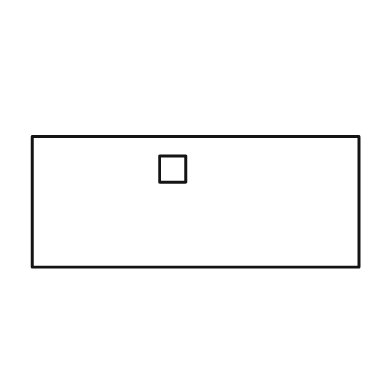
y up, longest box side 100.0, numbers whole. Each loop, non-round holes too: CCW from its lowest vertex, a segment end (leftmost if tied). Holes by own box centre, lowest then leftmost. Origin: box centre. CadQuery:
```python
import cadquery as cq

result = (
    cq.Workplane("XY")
    .moveTo(-50.0, -20.0)
    .lineTo(50.0, -20.0)
    .lineTo(50.0, 20.0)
    .lineTo(-50.0, 20.0)
    .close()
    .moveTo(-11.0, 6.0)
    .lineTo(-3.0, 6.0)
    .lineTo(-3.0, 14.0)
    .lineTo(-11.0, 14.0)
    .close()
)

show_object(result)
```